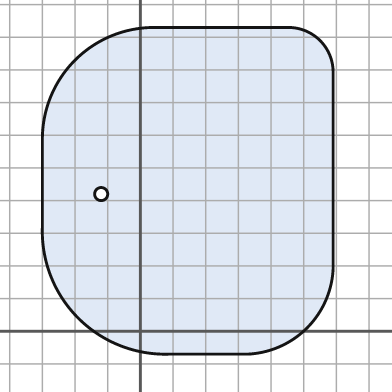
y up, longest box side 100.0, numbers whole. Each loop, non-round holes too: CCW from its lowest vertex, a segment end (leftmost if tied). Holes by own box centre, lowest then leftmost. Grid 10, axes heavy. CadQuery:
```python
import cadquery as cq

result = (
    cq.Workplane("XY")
    .moveTo(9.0, -7.0)
    .lineTo(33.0, -7.0)
    .threePointArc((51.0, 1.0), (59.0, 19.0))
    .lineTo(59.0, 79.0)
    .threePointArc((55.0, 89.0), (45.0, 93.0))
    .lineTo(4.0, 93.0)
    .threePointArc((-20.0, 83.0), (-30.0, 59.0))
    .lineTo(-30.0, 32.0)
    .threePointArc((-19.0, 4.0), (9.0, -7.0))
    .close()
    .moveTo(-12.0, 42.0)
    .circle(2.0)
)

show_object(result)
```